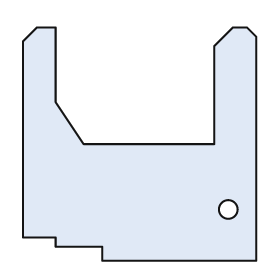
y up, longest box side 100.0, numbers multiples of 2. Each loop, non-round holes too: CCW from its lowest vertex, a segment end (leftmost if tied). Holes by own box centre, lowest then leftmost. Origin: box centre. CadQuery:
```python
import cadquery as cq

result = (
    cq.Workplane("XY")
    .moveTo(-16.0, -50.0)
    .lineTo(50.0, -50.0)
    .lineTo(50.0, 46.0)
    .lineTo(46.0, 50.0)
    .lineTo(40.0, 50.0)
    .lineTo(32.0, 42.0)
    .lineTo(32.0, 0.0)
    .lineTo(-24.0, 0.0)
    .lineTo(-36.0, 18.0)
    .lineTo(-36.0, 50.0)
    .lineTo(-44.0, 50.0)
    .lineTo(-50.0, 44.0)
    .lineTo(-50.0, -40.0)
    .lineTo(-36.0, -40.0)
    .lineTo(-36.0, -44.0)
    .lineTo(-16.0, -44.0)
    .close()
    .moveTo(38.0, -28.0)
    .circle(4.0)
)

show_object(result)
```